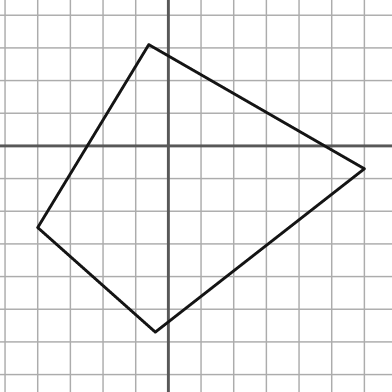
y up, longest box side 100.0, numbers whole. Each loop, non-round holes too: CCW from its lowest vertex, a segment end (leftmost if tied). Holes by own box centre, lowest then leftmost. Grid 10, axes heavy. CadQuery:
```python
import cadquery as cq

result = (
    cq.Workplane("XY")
    .moveTo(-4.0, -57.0)
    .lineTo(60.0, -7.0)
    .lineTo(-6.0, 31.0)
    .lineTo(-40.0, -25.0)
    .close()
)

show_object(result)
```